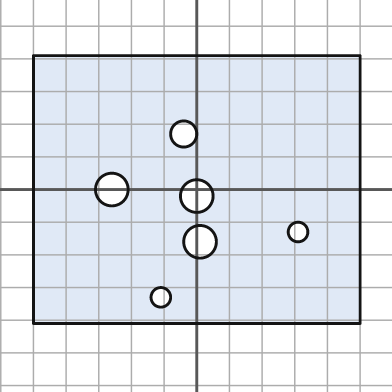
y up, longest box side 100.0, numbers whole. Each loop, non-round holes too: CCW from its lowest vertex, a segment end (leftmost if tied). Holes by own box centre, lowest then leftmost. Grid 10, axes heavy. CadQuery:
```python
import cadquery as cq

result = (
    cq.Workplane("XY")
    .moveTo(-50.0, -41.0)
    .lineTo(50.0, -41.0)
    .lineTo(50.0, 41.0)
    .lineTo(-50.0, 41.0)
    .close()
    .moveTo(-11.0, -33.0)
    .circle(3.0)
    .moveTo(1.0, -16.0)
    .circle(5.0)
    .moveTo(31.0, -13.0)
    .circle(3.0)
    .moveTo(0.0, -2.0)
    .circle(5.0)
    .moveTo(-26.0, 0.0)
    .circle(5.0)
    .moveTo(-4.0, 17.0)
    .circle(4.0)
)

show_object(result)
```